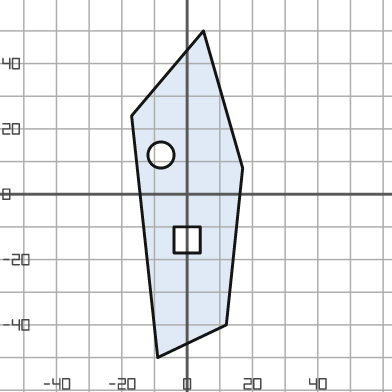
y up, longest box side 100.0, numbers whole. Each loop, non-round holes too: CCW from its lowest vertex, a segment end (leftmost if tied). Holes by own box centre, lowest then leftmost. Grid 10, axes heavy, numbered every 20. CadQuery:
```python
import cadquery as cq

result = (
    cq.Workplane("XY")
    .moveTo(-9.0, -50.0)
    .lineTo(12.0, -40.0)
    .lineTo(17.0, 8.0)
    .lineTo(5.0, 50.0)
    .lineTo(-17.0, 24.0)
    .close()
    .moveTo(-4.0, -18.0)
    .lineTo(4.0, -18.0)
    .lineTo(4.0, -10.0)
    .lineTo(-4.0, -10.0)
    .close()
    .moveTo(-8.0, 12.0)
    .circle(4.0)
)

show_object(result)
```